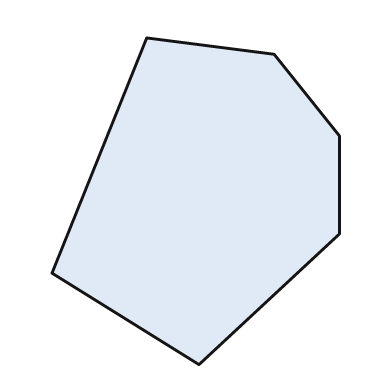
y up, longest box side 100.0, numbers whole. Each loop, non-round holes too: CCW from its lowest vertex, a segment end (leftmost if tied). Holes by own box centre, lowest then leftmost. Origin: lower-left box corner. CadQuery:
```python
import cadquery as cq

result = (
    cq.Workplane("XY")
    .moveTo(45.0, 0.0)
    .lineTo(88.0, 40.0)
    .lineTo(88.0, 70.0)
    .lineTo(68.0, 95.0)
    .lineTo(29.0, 100.0)
    .lineTo(0.0, 28.0)
    .close()
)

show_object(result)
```